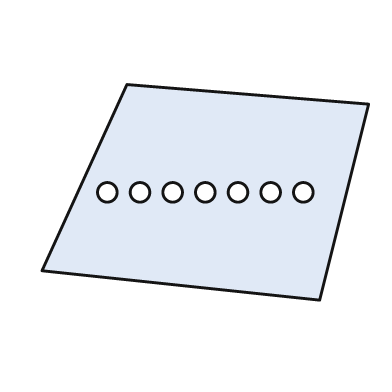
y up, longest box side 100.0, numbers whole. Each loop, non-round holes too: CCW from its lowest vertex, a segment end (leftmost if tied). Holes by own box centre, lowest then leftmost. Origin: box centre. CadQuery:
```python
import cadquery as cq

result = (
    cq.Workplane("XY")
    .moveTo(35.0, -33.0)
    .lineTo(50.0, 27.0)
    .lineTo(-24.0, 33.0)
    .lineTo(-50.0, -24.0)
    .close()
    .moveTo(-30.0, 0.0)
    .circle(3.0)
    .moveTo(-20.0, 0.0)
    .circle(3.0)
    .moveTo(-10.0, 0.0)
    .circle(3.0)
    .moveTo(0.0, 0.0)
    .circle(3.0)
    .moveTo(10.0, 0.0)
    .circle(3.0)
    .moveTo(20.0, 0.0)
    .circle(3.0)
    .moveTo(30.0, 0.0)
    .circle(3.0)
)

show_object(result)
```